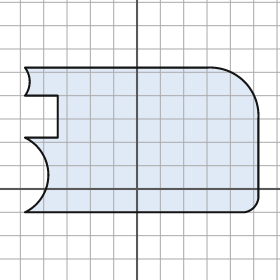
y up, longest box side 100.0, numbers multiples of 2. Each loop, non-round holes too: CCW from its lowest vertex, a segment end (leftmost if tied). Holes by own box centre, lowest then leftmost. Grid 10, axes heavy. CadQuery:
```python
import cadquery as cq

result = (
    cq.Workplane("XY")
    .moveTo(-48.0, -10.0)
    .lineTo(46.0, -10.0)
    .threePointArc((50.0, -8.0), (52.0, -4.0))
    .lineTo(52.0, 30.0)
    .threePointArc((46.0, 46.0), (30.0, 52.0))
    .lineTo(-48.0, 52.0)
    .threePointArc((-46.0, 46.0), (-48.0, 40.0))
    .lineTo(-34.0, 40.0)
    .lineTo(-34.0, 22.0)
    .lineTo(-48.0, 22.0)
    .threePointArc((-38.0, 6.0), (-48.0, -10.0))
    .close()
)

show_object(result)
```